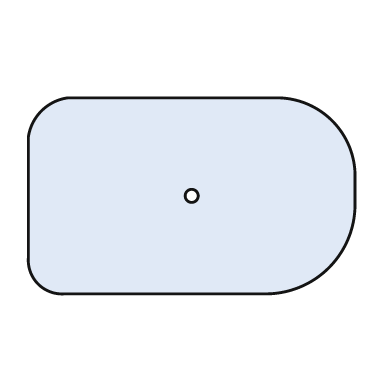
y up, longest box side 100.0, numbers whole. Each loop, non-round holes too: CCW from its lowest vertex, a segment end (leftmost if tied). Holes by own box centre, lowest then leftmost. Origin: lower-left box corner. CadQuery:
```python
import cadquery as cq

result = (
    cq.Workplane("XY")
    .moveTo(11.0, 0.0)
    .lineTo(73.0, 0.0)
    .threePointArc((92.0, 8.0), (100.0, 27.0))
    .lineTo(100.0, 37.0)
    .threePointArc((93.0, 53.0), (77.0, 60.0))
    .lineTo(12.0, 60.0)
    .threePointArc((4.0, 56.0), (0.0, 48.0))
    .lineTo(0.0, 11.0)
    .threePointArc((3.0, 3.0), (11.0, 0.0))
    .close()
    .moveTo(50.0, 30.0)
    .circle(2.0)
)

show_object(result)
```